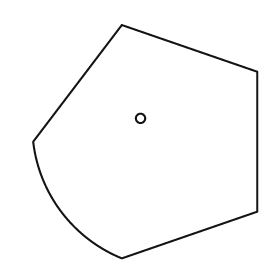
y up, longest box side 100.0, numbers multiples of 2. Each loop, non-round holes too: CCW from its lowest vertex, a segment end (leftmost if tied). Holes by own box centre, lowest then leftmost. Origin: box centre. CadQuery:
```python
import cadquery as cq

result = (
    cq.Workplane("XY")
    .moveTo(-10.0, -50.0)
    .lineTo(48.0, -30.0)
    .lineTo(48.0, 30.0)
    .lineTo(-10.0, 50.0)
    .lineTo(-48.0, 0.0)
    .threePointArc((-36.0, -30.0), (-10.0, -50.0))
    .close()
    .moveTo(-2.0, 10.0)
    .circle(2.0)
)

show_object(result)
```